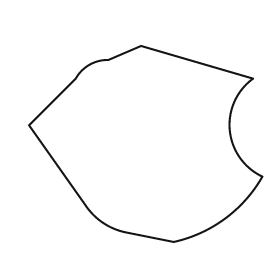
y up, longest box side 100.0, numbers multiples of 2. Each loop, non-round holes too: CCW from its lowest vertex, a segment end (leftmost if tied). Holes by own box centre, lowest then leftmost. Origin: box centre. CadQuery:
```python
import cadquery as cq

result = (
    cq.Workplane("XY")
    .moveTo(12.0, -42.0)
    .threePointArc((34.0, -32.0), (50.0, -14.0))
    .threePointArc((36.0, 6.0), (46.0, 28.0))
    .lineTo(-2.0, 42.0)
    .lineTo(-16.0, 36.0)
    .threePointArc((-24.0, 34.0), (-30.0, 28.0))
    .lineTo(-50.0, 8.0)
    .lineTo(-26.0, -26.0)
    .threePointArc((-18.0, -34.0), (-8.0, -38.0))
    .close()
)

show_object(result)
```